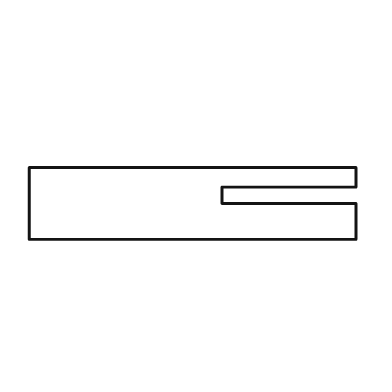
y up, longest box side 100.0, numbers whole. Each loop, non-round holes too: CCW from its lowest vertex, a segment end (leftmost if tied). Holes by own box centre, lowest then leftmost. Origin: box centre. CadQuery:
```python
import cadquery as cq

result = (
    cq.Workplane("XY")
    .moveTo(-50.0, -11.0)
    .lineTo(50.0, -11.0)
    .lineTo(50.0, 0.0)
    .lineTo(9.0, 0.0)
    .lineTo(9.0, 5.0)
    .lineTo(50.0, 5.0)
    .lineTo(50.0, 11.0)
    .lineTo(-50.0, 11.0)
    .close()
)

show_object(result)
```